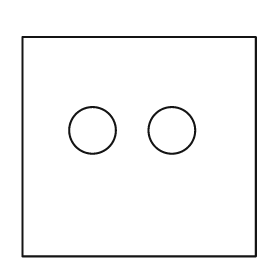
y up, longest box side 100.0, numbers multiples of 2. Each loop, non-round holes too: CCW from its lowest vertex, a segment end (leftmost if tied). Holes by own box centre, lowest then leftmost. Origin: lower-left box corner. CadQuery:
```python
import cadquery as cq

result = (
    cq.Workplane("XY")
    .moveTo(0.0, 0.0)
    .lineTo(100.0, 0.0)
    .lineTo(100.0, 94.0)
    .lineTo(0.0, 94.0)
    .close()
    .moveTo(30.0, 54.0)
    .circle(10.0)
    .moveTo(64.0, 54.0)
    .circle(10.0)
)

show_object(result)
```